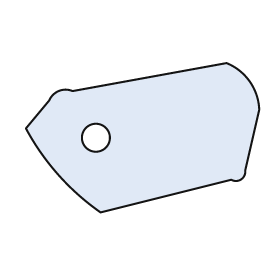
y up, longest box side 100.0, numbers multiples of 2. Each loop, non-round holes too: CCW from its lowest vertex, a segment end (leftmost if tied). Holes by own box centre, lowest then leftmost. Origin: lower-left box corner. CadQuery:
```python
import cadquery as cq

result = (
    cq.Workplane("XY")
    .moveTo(32.0, 0.0)
    .lineTo(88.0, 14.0)
    .threePointArc((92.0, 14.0), (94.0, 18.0))
    .lineTo(100.0, 44.0)
    .threePointArc((96.0, 56.0), (86.0, 64.0))
    .lineTo(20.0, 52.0)
    .threePointArc((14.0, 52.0), (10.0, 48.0))
    .lineTo(0.0, 36.0)
    .threePointArc((14.0, 16.0), (32.0, 0.0))
    .close()
    .moveTo(30.0, 32.0)
    .circle(6.0)
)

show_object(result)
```